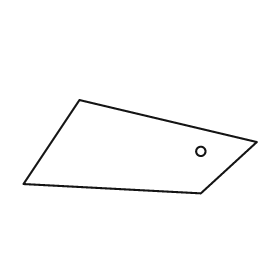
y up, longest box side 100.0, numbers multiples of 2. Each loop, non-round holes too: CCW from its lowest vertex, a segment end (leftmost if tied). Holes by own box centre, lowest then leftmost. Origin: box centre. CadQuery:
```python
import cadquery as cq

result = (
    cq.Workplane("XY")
    .moveTo(26.0, -20.0)
    .lineTo(50.0, 2.0)
    .lineTo(-26.0, 20.0)
    .lineTo(-50.0, -16.0)
    .close()
    .moveTo(26.0, -2.0)
    .circle(2.0)
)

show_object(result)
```